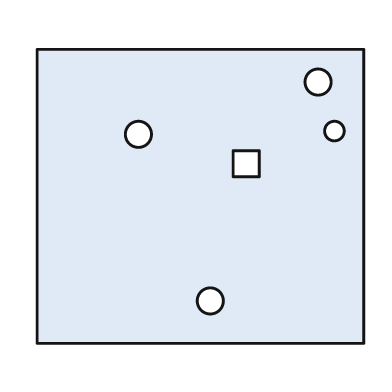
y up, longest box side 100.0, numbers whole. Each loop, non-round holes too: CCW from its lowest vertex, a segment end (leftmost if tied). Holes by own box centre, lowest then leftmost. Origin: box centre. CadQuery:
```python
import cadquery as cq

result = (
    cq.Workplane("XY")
    .moveTo(-50.0, -45.0)
    .lineTo(50.0, -45.0)
    .lineTo(50.0, 45.0)
    .lineTo(-50.0, 45.0)
    .close()
    .moveTo(3.0, -32.0)
    .circle(4.0)
    .moveTo(10.0, 6.0)
    .lineTo(18.0, 6.0)
    .lineTo(18.0, 14.0)
    .lineTo(10.0, 14.0)
    .close()
    .moveTo(-19.0, 19.0)
    .circle(4.0)
    .moveTo(41.0, 20.0)
    .circle(3.0)
    .moveTo(36.0, 35.0)
    .circle(4.0)
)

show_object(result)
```